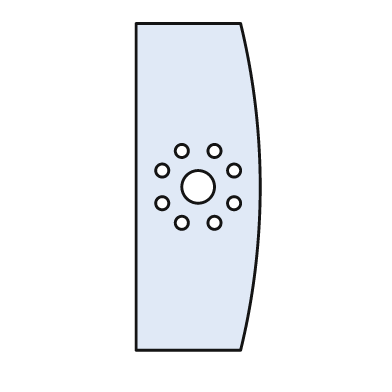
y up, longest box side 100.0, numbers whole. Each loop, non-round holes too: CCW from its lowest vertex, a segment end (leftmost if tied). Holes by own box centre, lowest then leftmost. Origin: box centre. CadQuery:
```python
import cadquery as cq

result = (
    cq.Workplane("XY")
    .moveTo(-19.0, -50.0)
    .lineTo(13.0, -50.0)
    .threePointArc((19.0, 0.0), (13.0, 50.0))
    .lineTo(-19.0, 50.0)
    .close()
    .moveTo(-5.0, -11.0)
    .circle(2.0)
    .moveTo(5.0, -11.0)
    .circle(2.0)
    .moveTo(-11.0, -5.0)
    .circle(2.0)
    .moveTo(11.0, -5.0)
    .circle(2.0)
    .moveTo(0.0, 0.0)
    .circle(5.0)
    .moveTo(-11.0, 5.0)
    .circle(2.0)
    .moveTo(11.0, 5.0)
    .circle(2.0)
    .moveTo(-5.0, 11.0)
    .circle(2.0)
    .moveTo(5.0, 11.0)
    .circle(2.0)
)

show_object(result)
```